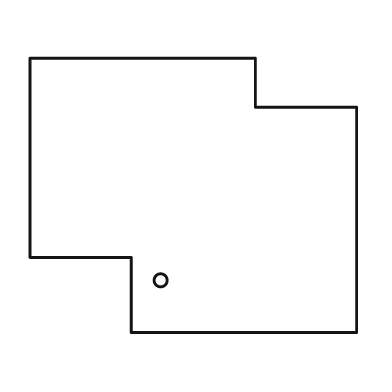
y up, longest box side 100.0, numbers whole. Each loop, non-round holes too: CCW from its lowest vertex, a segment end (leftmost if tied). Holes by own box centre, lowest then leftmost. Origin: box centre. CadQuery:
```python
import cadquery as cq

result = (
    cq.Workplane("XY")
    .moveTo(-19.0, -42.0)
    .lineTo(50.0, -42.0)
    .lineTo(50.0, 27.0)
    .lineTo(19.0, 27.0)
    .lineTo(19.0, 42.0)
    .lineTo(-50.0, 42.0)
    .lineTo(-50.0, -19.0)
    .lineTo(-19.0, -19.0)
    .close()
    .moveTo(-10.0, -26.0)
    .circle(2.0)
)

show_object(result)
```